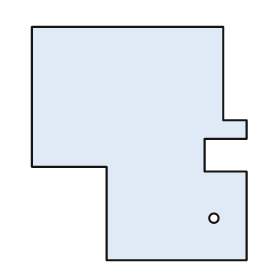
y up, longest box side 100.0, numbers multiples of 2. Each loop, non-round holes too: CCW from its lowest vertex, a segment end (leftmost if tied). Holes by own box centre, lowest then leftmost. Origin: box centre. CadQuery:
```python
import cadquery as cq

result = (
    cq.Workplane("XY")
    .moveTo(-14.0, -50.0)
    .lineTo(46.0, -50.0)
    .lineTo(46.0, -12.0)
    .lineTo(28.0, -12.0)
    .lineTo(28.0, 2.0)
    .lineTo(46.0, 2.0)
    .lineTo(46.0, 10.0)
    .lineTo(36.0, 10.0)
    .lineTo(36.0, 50.0)
    .lineTo(-46.0, 50.0)
    .lineTo(-46.0, -10.0)
    .lineTo(-14.0, -10.0)
    .close()
    .moveTo(32.0, -32.0)
    .circle(2.0)
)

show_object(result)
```